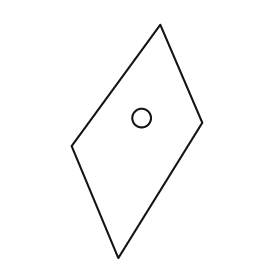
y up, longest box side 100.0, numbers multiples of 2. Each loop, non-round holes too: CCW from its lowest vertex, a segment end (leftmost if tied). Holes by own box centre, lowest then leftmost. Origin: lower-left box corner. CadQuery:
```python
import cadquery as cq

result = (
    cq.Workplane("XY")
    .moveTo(20.0, 0.0)
    .lineTo(56.0, 58.0)
    .lineTo(38.0, 100.0)
    .lineTo(0.0, 48.0)
    .close()
    .moveTo(30.0, 60.0)
    .circle(4.0)
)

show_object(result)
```